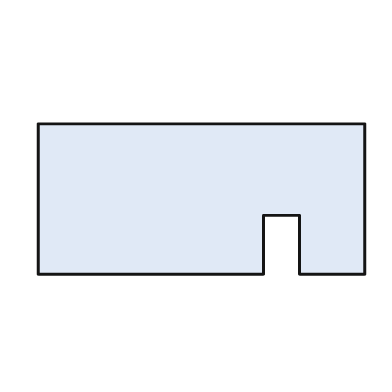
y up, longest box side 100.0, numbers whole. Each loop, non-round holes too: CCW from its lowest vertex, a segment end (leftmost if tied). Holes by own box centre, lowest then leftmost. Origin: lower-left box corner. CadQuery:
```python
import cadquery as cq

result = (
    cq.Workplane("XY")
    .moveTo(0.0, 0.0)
    .lineTo(69.0, 0.0)
    .lineTo(69.0, 18.0)
    .lineTo(80.0, 18.0)
    .lineTo(80.0, 0.0)
    .lineTo(100.0, 0.0)
    .lineTo(100.0, 46.0)
    .lineTo(0.0, 46.0)
    .close()
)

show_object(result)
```